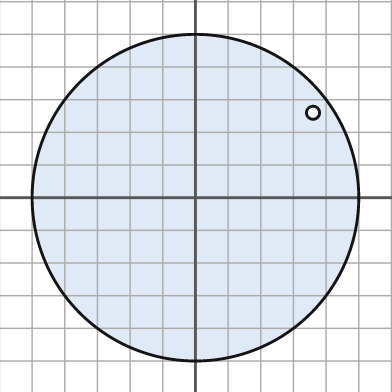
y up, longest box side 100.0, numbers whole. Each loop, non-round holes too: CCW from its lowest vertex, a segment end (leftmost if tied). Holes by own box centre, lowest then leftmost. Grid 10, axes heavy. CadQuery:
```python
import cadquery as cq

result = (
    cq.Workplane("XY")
    .moveTo(0.0, 0.0)
    .circle(50.0)
    .moveTo(36.0, 26.0)
    .circle(2.0)
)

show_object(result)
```